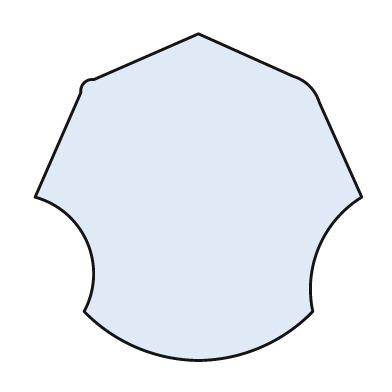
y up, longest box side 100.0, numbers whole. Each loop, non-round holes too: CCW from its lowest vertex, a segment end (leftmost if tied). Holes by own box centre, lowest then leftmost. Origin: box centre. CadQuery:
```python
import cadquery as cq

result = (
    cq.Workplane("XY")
    .moveTo(0.0, -50.0)
    .threePointArc((19.0, -46.0), (35.0, -35.0))
    .threePointArc((37.0, -15.0), (50.0, 0.0))
    .lineTo(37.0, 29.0)
    .threePointArc((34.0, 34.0), (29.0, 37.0))
    .lineTo(0.0, 50.0)
    .lineTo(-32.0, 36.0)
    .threePointArc((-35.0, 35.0), (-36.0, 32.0))
    .lineTo(-50.0, 0.0)
    .threePointArc((-34.0, -14.0), (-35.0, -35.0))
    .threePointArc((-19.0, -46.0), (0.0, -50.0))
    .close()
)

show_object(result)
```